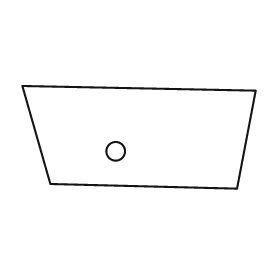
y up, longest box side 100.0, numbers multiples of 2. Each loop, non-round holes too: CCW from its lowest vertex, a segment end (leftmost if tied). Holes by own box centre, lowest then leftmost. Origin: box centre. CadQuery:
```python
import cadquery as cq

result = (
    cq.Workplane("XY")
    .moveTo(42.0, -22.0)
    .lineTo(50.0, 20.0)
    .lineTo(-50.0, 22.0)
    .lineTo(-38.0, -20.0)
    .close()
    .moveTo(-10.0, -6.0)
    .circle(4.0)
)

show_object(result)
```